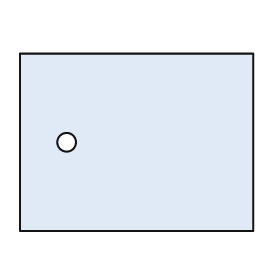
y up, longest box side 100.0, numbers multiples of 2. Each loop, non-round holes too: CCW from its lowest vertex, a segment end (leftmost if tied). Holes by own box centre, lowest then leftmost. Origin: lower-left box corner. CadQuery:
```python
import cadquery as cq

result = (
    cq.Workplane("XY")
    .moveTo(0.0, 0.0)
    .lineTo(100.0, 0.0)
    .lineTo(100.0, 76.0)
    .lineTo(0.0, 76.0)
    .close()
    .moveTo(20.0, 38.0)
    .circle(4.0)
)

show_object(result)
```